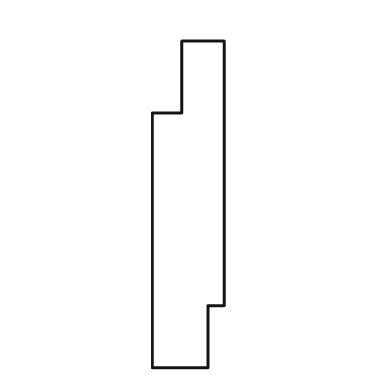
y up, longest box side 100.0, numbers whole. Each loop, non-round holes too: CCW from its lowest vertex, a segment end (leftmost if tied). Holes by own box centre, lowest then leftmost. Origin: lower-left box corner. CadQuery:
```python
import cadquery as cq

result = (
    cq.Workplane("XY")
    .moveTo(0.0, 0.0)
    .lineTo(17.0, 0.0)
    .lineTo(17.0, 19.0)
    .lineTo(22.0, 19.0)
    .lineTo(22.0, 100.0)
    .lineTo(9.0, 100.0)
    .lineTo(9.0, 78.0)
    .lineTo(0.0, 78.0)
    .close()
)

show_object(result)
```